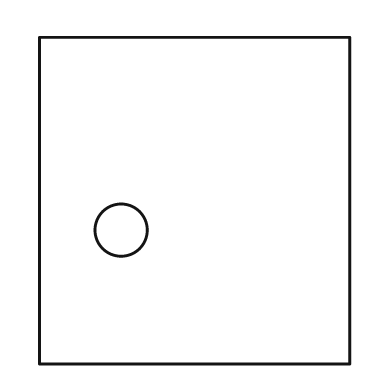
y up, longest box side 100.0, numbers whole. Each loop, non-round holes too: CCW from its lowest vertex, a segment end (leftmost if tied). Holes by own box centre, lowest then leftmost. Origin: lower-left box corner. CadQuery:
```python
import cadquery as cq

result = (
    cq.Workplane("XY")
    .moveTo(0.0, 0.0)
    .lineTo(95.0, 0.0)
    .lineTo(95.0, 100.0)
    .lineTo(0.0, 100.0)
    .close()
    .moveTo(25.0, 41.0)
    .circle(8.0)
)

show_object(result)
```